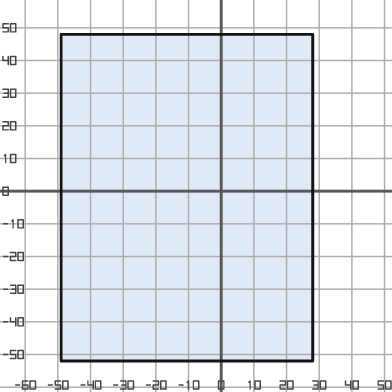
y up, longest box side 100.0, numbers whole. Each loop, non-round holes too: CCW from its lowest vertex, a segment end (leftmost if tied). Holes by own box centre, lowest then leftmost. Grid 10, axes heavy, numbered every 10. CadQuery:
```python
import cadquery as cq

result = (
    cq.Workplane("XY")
    .moveTo(-49.0, -52.0)
    .lineTo(28.0, -52.0)
    .lineTo(28.0, 48.0)
    .lineTo(-49.0, 48.0)
    .close()
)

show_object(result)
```